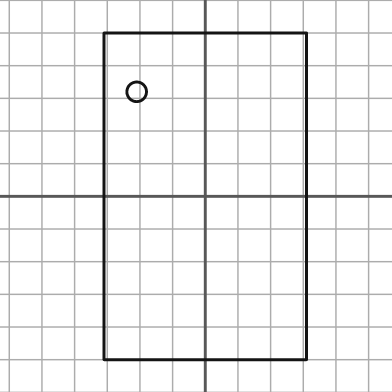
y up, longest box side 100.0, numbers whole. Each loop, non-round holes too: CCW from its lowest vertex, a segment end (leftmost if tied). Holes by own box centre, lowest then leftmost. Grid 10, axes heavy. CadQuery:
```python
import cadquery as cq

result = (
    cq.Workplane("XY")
    .moveTo(-31.0, -50.0)
    .lineTo(31.0, -50.0)
    .lineTo(31.0, 50.0)
    .lineTo(-31.0, 50.0)
    .close()
    .moveTo(-21.0, 32.0)
    .circle(3.0)
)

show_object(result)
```